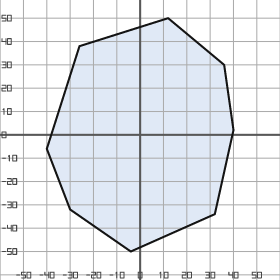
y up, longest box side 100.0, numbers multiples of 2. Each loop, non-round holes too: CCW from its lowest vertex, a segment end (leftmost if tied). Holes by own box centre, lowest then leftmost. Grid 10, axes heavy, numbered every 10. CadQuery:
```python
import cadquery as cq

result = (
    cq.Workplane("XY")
    .moveTo(-4.0, -50.0)
    .lineTo(32.0, -34.0)
    .lineTo(40.0, 2.0)
    .lineTo(36.0, 30.0)
    .lineTo(12.0, 50.0)
    .lineTo(-26.0, 38.0)
    .lineTo(-40.0, -6.0)
    .lineTo(-30.0, -32.0)
    .close()
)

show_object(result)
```